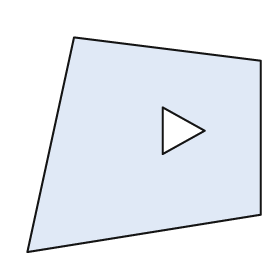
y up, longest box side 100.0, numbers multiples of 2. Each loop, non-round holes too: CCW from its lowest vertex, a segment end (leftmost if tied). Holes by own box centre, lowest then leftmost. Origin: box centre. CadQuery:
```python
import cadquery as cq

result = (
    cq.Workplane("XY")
    .moveTo(-50.0, -46.0)
    .lineTo(50.0, -30.0)
    .lineTo(50.0, 36.0)
    .lineTo(-30.0, 46.0)
    .close()
    .moveTo(8.0, -4.0)
    .lineTo(26.0, 6.0)
    .lineTo(8.0, 16.0)
    .close()
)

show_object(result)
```